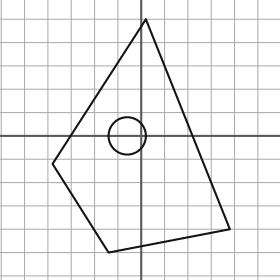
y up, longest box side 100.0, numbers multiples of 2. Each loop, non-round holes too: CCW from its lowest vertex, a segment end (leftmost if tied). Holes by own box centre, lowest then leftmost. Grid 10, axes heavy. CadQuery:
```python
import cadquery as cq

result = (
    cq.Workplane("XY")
    .moveTo(-14.0, -50.0)
    .lineTo(38.0, -40.0)
    .lineTo(2.0, 50.0)
    .lineTo(-38.0, -12.0)
    .close()
    .moveTo(-6.0, 0.0)
    .circle(8.0)
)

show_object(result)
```